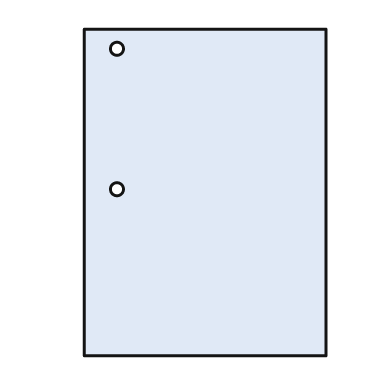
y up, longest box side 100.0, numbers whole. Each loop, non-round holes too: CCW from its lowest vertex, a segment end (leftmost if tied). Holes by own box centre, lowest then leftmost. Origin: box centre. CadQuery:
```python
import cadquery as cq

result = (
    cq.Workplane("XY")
    .moveTo(-37.0, -50.0)
    .lineTo(37.0, -50.0)
    .lineTo(37.0, 50.0)
    .lineTo(-37.0, 50.0)
    .close()
    .moveTo(-27.0, 1.0)
    .circle(2.0)
    .moveTo(-27.0, 44.0)
    .circle(2.0)
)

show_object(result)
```